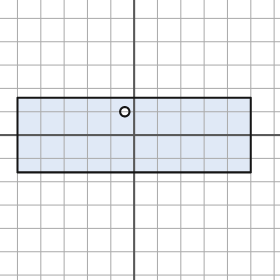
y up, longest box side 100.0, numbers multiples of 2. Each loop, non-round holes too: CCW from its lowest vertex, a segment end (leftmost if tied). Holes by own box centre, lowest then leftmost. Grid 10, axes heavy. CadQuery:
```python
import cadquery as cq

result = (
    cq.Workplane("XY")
    .moveTo(-50.0, -16.0)
    .lineTo(50.0, -16.0)
    .lineTo(50.0, 16.0)
    .lineTo(-50.0, 16.0)
    .close()
    .moveTo(-4.0, 10.0)
    .circle(2.0)
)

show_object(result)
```